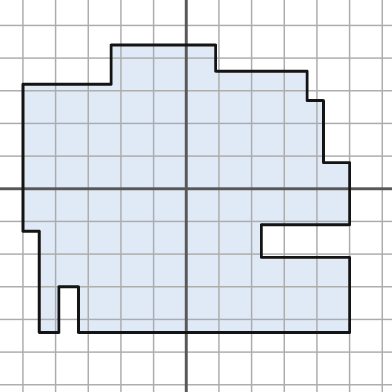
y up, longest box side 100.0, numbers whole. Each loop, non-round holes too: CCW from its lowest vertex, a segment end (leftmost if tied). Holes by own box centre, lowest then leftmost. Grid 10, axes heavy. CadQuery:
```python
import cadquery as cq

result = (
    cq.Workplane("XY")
    .moveTo(-45.0, -44.0)
    .lineTo(-39.0, -44.0)
    .lineTo(-39.0, -30.0)
    .lineTo(-33.0, -30.0)
    .lineTo(-33.0, -44.0)
    .lineTo(50.0, -44.0)
    .lineTo(50.0, -21.0)
    .lineTo(23.0, -21.0)
    .lineTo(23.0, -11.0)
    .lineTo(50.0, -11.0)
    .lineTo(50.0, 8.0)
    .lineTo(42.0, 8.0)
    .lineTo(42.0, 27.0)
    .lineTo(37.0, 27.0)
    .lineTo(37.0, 36.0)
    .lineTo(9.0, 36.0)
    .lineTo(9.0, 44.0)
    .lineTo(-23.0, 44.0)
    .lineTo(-23.0, 32.0)
    .lineTo(-50.0, 32.0)
    .lineTo(-50.0, -13.0)
    .lineTo(-45.0, -13.0)
    .close()
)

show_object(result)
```